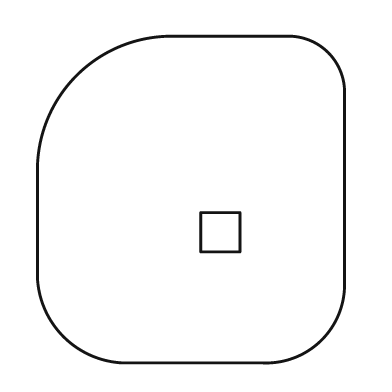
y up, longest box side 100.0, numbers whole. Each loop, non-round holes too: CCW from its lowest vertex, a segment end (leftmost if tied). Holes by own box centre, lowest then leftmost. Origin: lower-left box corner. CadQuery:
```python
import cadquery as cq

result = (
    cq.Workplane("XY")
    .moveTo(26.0, 0.0)
    .lineTo(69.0, 0.0)
    .threePointArc((87.0, 7.0), (94.0, 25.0))
    .lineTo(94.0, 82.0)
    .threePointArc((89.0, 95.0), (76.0, 100.0))
    .lineTo(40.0, 100.0)
    .threePointArc((12.0, 88.0), (0.0, 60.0))
    .lineTo(0.0, 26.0)
    .threePointArc((8.0, 8.0), (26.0, 0.0))
    .close()
    .moveTo(50.0, 34.0)
    .lineTo(62.0, 34.0)
    .lineTo(62.0, 46.0)
    .lineTo(50.0, 46.0)
    .close()
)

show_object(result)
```